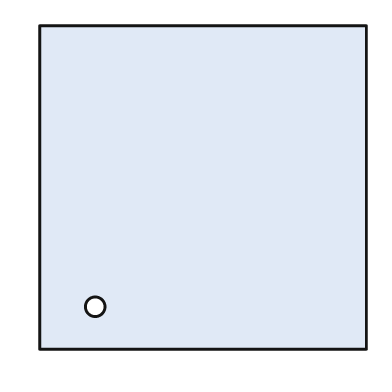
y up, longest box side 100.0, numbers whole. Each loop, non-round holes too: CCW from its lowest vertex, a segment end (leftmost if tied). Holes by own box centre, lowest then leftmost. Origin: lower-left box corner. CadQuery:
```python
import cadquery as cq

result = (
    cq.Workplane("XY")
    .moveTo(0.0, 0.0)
    .lineTo(100.0, 0.0)
    .lineTo(100.0, 99.0)
    .lineTo(0.0, 99.0)
    .close()
    .moveTo(17.0, 13.0)
    .circle(3.0)
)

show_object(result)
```